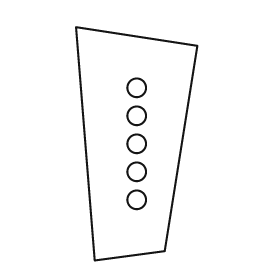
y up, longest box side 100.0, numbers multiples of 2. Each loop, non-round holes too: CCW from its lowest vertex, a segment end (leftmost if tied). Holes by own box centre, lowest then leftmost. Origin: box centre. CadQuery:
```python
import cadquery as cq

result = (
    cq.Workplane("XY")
    .moveTo(-18.0, -50.0)
    .lineTo(12.0, -46.0)
    .lineTo(26.0, 42.0)
    .lineTo(-26.0, 50.0)
    .close()
    .moveTo(0.0, -24.0)
    .circle(4.0)
    .moveTo(0.0, -12.0)
    .circle(4.0)
    .moveTo(0.0, 0.0)
    .circle(4.0)
    .moveTo(0.0, 12.0)
    .circle(4.0)
    .moveTo(0.0, 24.0)
    .circle(4.0)
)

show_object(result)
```